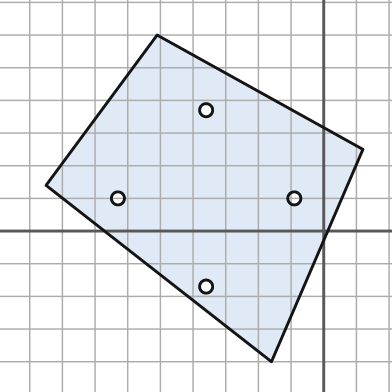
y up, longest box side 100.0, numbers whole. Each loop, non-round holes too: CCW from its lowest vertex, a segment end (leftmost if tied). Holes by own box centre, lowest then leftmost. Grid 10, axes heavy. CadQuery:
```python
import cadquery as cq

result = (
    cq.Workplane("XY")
    .moveTo(-16.0, -40.0)
    .lineTo(12.0, 25.0)
    .lineTo(-51.0, 60.0)
    .lineTo(-85.0, 14.0)
    .close()
    .moveTo(-36.0, -17.0)
    .circle(2.0)
    .moveTo(-63.0, 10.0)
    .circle(2.0)
    .moveTo(-9.0, 10.0)
    .circle(2.0)
    .moveTo(-36.0, 37.0)
    .circle(2.0)
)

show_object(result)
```